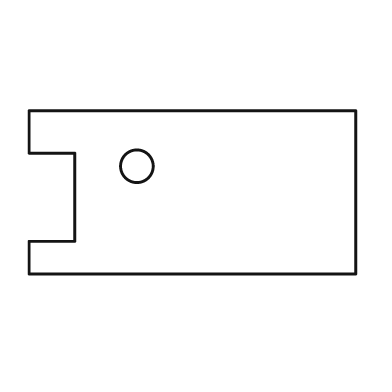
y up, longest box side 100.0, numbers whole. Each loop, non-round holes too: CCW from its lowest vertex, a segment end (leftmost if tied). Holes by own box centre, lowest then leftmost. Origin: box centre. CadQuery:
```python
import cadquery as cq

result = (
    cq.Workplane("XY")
    .moveTo(-50.0, -25.0)
    .lineTo(50.0, -25.0)
    .lineTo(50.0, 25.0)
    .lineTo(-50.0, 25.0)
    .lineTo(-50.0, 12.0)
    .lineTo(-36.0, 12.0)
    .lineTo(-36.0, -15.0)
    .lineTo(-50.0, -15.0)
    .close()
    .moveTo(-17.0, 8.0)
    .circle(5.0)
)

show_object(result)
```